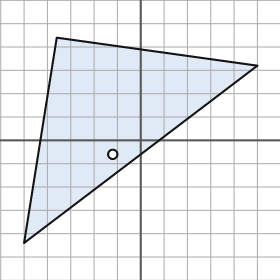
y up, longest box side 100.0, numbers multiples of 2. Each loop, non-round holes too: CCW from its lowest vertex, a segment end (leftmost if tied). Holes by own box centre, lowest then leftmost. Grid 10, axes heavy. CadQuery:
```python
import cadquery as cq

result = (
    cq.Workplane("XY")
    .moveTo(-50.0, -44.0)
    .lineTo(50.0, 32.0)
    .lineTo(-36.0, 44.0)
    .close()
    .moveTo(-12.0, -6.0)
    .circle(2.0)
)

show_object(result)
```